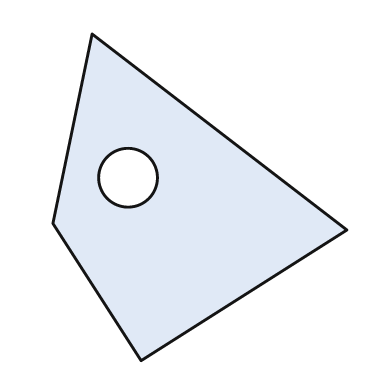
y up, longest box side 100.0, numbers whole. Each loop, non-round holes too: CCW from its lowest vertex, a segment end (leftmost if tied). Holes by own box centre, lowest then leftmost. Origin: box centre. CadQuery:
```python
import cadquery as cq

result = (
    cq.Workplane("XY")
    .moveTo(-18.0, -50.0)
    .lineTo(45.0, -10.0)
    .lineTo(-33.0, 50.0)
    .lineTo(-45.0, -8.0)
    .close()
    .moveTo(-22.0, 6.0)
    .circle(9.0)
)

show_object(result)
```